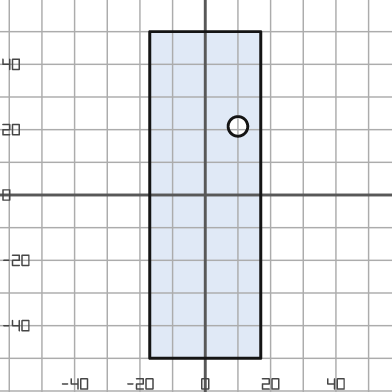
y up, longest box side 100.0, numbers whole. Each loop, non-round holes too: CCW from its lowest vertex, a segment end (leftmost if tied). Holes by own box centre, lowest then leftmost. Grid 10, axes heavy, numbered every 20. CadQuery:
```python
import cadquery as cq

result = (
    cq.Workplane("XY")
    .moveTo(-17.0, -50.0)
    .lineTo(17.0, -50.0)
    .lineTo(17.0, 50.0)
    .lineTo(-17.0, 50.0)
    .close()
    .moveTo(10.0, 21.0)
    .circle(3.0)
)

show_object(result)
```